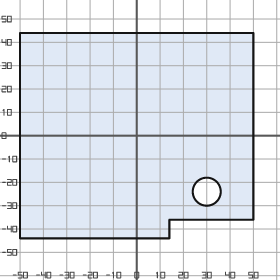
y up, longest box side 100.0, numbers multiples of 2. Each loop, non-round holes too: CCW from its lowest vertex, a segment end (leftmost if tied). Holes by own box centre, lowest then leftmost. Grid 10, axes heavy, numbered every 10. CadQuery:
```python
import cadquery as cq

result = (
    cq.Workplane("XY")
    .moveTo(-50.0, -44.0)
    .lineTo(14.0, -44.0)
    .lineTo(14.0, -36.0)
    .lineTo(50.0, -36.0)
    .lineTo(50.0, 44.0)
    .lineTo(-50.0, 44.0)
    .close()
    .moveTo(30.0, -24.0)
    .circle(6.0)
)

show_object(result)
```